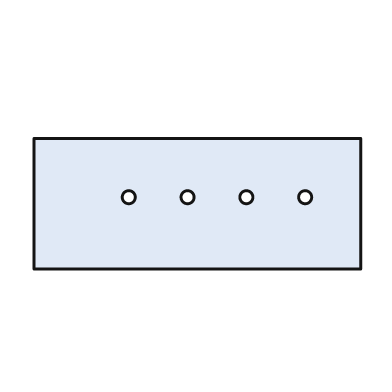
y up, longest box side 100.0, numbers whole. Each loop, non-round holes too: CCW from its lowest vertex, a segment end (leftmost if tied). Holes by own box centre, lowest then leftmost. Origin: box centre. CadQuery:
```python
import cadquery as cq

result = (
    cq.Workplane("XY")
    .moveTo(-50.0, -20.0)
    .lineTo(50.0, -20.0)
    .lineTo(50.0, 20.0)
    .lineTo(-50.0, 20.0)
    .close()
    .moveTo(-21.0, 2.0)
    .circle(2.0)
    .moveTo(-3.0, 2.0)
    .circle(2.0)
    .moveTo(15.0, 2.0)
    .circle(2.0)
    .moveTo(33.0, 2.0)
    .circle(2.0)
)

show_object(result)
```